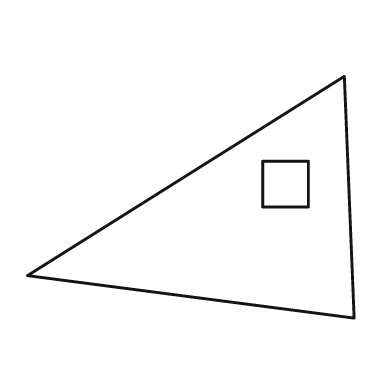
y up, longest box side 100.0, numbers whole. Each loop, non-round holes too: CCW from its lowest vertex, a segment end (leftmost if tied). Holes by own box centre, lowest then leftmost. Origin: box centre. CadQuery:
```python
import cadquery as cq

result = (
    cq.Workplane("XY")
    .moveTo(50.0, -37.0)
    .lineTo(47.0, 37.0)
    .lineTo(-50.0, -24.0)
    .close()
    .moveTo(22.0, -3.0)
    .lineTo(36.0, -3.0)
    .lineTo(36.0, 11.0)
    .lineTo(22.0, 11.0)
    .close()
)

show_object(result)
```